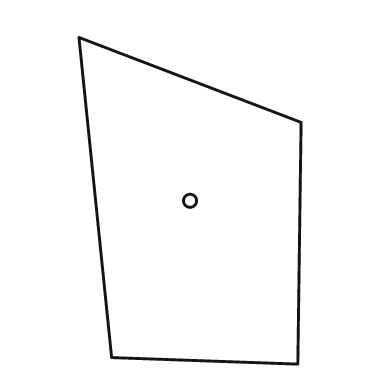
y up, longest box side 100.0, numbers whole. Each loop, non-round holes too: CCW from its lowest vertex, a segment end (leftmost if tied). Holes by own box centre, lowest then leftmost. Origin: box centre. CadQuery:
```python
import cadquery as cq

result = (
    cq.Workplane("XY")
    .moveTo(33.0, -50.0)
    .lineTo(34.0, 24.0)
    .lineTo(-34.0, 50.0)
    .lineTo(-24.0, -48.0)
    .close()
    .moveTo(0.0, 0.0)
    .circle(2.0)
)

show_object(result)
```